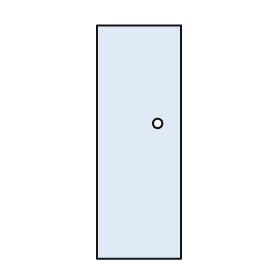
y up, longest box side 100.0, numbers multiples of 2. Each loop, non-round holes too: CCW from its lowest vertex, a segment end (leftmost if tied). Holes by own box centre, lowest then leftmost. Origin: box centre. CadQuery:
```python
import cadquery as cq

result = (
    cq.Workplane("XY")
    .moveTo(-18.0, -50.0)
    .lineTo(18.0, -50.0)
    .lineTo(18.0, 50.0)
    .lineTo(-18.0, 50.0)
    .close()
    .moveTo(8.0, 8.0)
    .circle(2.0)
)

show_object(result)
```